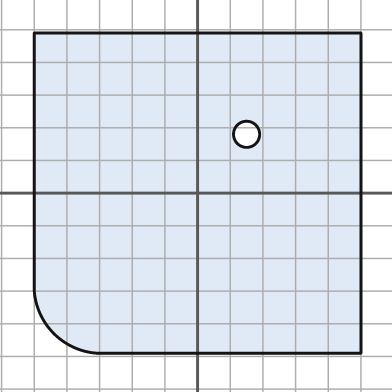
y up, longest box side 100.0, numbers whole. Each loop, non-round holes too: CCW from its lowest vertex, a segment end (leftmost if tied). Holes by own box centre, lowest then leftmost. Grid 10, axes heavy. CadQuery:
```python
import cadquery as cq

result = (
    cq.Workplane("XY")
    .moveTo(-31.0, -49.0)
    .lineTo(50.0, -49.0)
    .lineTo(50.0, 49.0)
    .lineTo(-50.0, 49.0)
    .lineTo(-50.0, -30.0)
    .threePointArc((-44.0, -43.0), (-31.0, -49.0))
    .close()
    .moveTo(15.0, 18.0)
    .circle(4.0)
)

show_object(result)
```